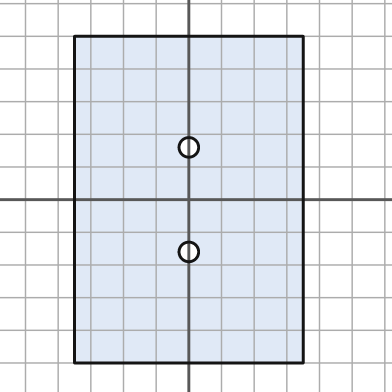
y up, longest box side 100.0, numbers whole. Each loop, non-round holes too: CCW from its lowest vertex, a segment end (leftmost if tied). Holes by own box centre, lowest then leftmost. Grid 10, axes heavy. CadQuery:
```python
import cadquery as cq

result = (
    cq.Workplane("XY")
    .moveTo(-35.0, -50.0)
    .lineTo(35.0, -50.0)
    .lineTo(35.0, 50.0)
    .lineTo(-35.0, 50.0)
    .close()
    .moveTo(0.0, -16.0)
    .circle(3.0)
    .moveTo(0.0, 16.0)
    .circle(3.0)
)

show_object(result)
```